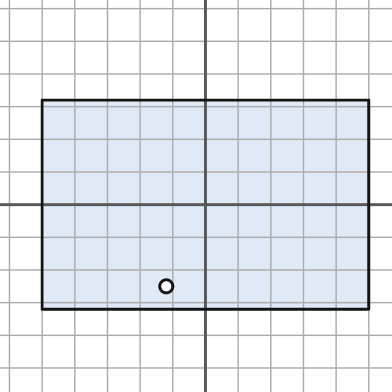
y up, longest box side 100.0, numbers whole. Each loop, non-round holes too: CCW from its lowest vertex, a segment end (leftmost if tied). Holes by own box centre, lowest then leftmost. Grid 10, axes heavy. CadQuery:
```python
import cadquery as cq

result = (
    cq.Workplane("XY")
    .moveTo(-50.0, -32.0)
    .lineTo(50.0, -32.0)
    .lineTo(50.0, 32.0)
    .lineTo(-50.0, 32.0)
    .close()
    .moveTo(-12.0, -25.0)
    .circle(2.0)
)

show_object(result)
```